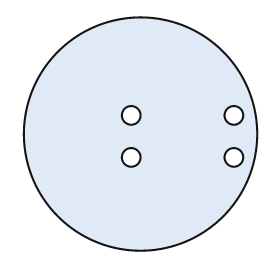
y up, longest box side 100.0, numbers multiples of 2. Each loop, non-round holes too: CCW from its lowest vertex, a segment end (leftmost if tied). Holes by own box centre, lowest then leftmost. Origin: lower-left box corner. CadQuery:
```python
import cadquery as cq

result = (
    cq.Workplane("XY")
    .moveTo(50.0, 50.0)
    .circle(50.0)
    .moveTo(46.0, 40.0)
    .circle(4.0)
    .moveTo(90.0, 40.0)
    .circle(4.0)
    .moveTo(46.0, 58.0)
    .circle(4.0)
    .moveTo(90.0, 58.0)
    .circle(4.0)
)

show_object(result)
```